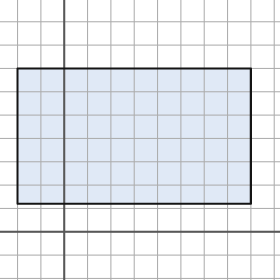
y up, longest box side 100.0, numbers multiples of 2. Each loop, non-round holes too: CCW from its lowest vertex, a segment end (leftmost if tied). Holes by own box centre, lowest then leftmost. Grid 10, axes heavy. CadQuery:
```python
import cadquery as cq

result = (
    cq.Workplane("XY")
    .moveTo(-20.0, 12.0)
    .lineTo(80.0, 12.0)
    .lineTo(80.0, 70.0)
    .lineTo(-20.0, 70.0)
    .close()
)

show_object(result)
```